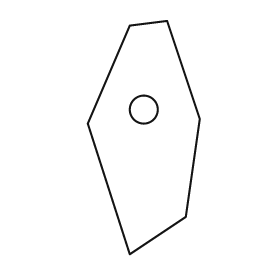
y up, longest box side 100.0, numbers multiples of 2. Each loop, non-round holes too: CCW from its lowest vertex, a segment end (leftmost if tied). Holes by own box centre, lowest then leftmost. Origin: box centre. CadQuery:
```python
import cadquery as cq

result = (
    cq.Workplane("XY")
    .moveTo(-6.0, -50.0)
    .lineTo(18.0, -34.0)
    .lineTo(24.0, 8.0)
    .lineTo(10.0, 50.0)
    .lineTo(-6.0, 48.0)
    .lineTo(-24.0, 6.0)
    .close()
    .moveTo(0.0, 12.0)
    .circle(6.0)
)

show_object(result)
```